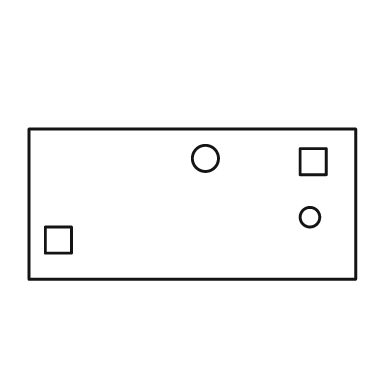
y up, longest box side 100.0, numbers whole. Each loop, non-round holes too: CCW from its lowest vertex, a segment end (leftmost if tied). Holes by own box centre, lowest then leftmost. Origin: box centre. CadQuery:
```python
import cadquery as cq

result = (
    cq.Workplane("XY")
    .moveTo(-50.0, -23.0)
    .lineTo(50.0, -23.0)
    .lineTo(50.0, 23.0)
    .lineTo(-50.0, 23.0)
    .close()
    .moveTo(-45.0, -15.0)
    .lineTo(-37.0, -15.0)
    .lineTo(-37.0, -7.0)
    .lineTo(-45.0, -7.0)
    .close()
    .moveTo(36.0, -4.0)
    .circle(3.0)
    .moveTo(33.0, 9.0)
    .lineTo(41.0, 9.0)
    .lineTo(41.0, 17.0)
    .lineTo(33.0, 17.0)
    .close()
    .moveTo(4.0, 14.0)
    .circle(4.0)
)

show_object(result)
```